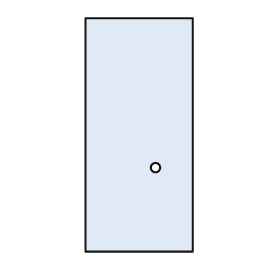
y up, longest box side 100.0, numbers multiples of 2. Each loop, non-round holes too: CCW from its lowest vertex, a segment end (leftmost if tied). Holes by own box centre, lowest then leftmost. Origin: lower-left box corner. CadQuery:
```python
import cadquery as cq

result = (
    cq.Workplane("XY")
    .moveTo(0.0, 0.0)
    .lineTo(46.0, 0.0)
    .lineTo(46.0, 100.0)
    .lineTo(0.0, 100.0)
    .close()
    .moveTo(30.0, 36.0)
    .circle(2.0)
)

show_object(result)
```